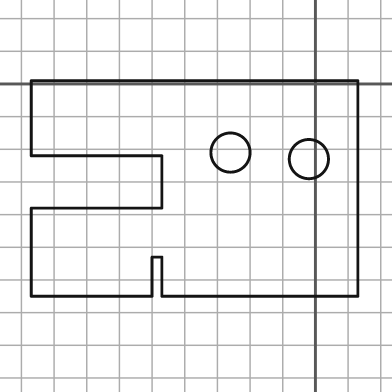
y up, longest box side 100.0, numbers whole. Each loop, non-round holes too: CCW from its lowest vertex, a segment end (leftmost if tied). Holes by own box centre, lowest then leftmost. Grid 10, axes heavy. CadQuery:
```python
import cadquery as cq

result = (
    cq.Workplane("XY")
    .moveTo(-87.0, -65.0)
    .lineTo(-50.0, -65.0)
    .lineTo(-50.0, -53.0)
    .lineTo(-47.0, -53.0)
    .lineTo(-47.0, -65.0)
    .lineTo(13.0, -65.0)
    .lineTo(13.0, 1.0)
    .lineTo(-87.0, 1.0)
    .lineTo(-87.0, -22.0)
    .lineTo(-47.0, -22.0)
    .lineTo(-47.0, -38.0)
    .lineTo(-87.0, -38.0)
    .close()
    .moveTo(-2.0, -23.0)
    .circle(6.0)
    .moveTo(-26.0, -21.0)
    .circle(6.0)
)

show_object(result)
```